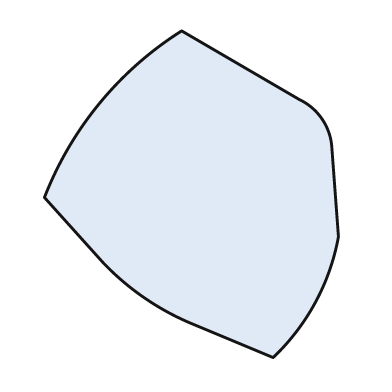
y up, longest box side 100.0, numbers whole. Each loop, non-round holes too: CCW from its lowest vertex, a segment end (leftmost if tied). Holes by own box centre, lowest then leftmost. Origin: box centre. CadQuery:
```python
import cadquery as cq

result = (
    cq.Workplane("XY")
    .moveTo(25.0, -50.0)
    .threePointArc((38.0, -33.0), (45.0, -13.0))
    .lineTo(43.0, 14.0)
    .threePointArc((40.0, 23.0), (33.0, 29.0))
    .lineTo(-3.0, 50.0)
    .threePointArc((-28.0, 28.0), (-45.0, -1.0))
    .lineTo(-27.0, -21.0)
    .threePointArc((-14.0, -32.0), (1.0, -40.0))
    .close()
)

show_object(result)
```